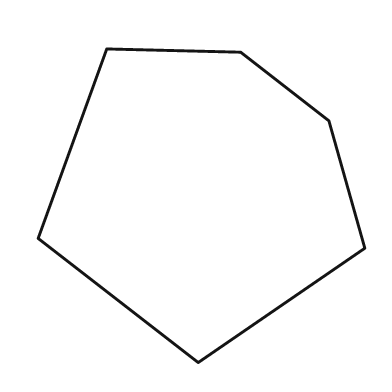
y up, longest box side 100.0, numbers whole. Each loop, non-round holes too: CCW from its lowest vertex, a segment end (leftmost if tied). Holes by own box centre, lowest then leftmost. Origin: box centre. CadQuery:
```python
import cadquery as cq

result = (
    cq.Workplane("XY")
    .moveTo(-1.0, -48.0)
    .lineTo(50.0, -13.0)
    .lineTo(39.0, 26.0)
    .lineTo(12.0, 47.0)
    .lineTo(-29.0, 48.0)
    .lineTo(-50.0, -10.0)
    .close()
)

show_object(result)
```